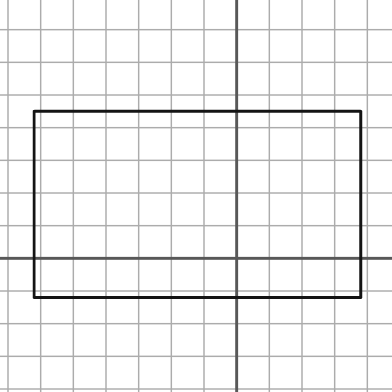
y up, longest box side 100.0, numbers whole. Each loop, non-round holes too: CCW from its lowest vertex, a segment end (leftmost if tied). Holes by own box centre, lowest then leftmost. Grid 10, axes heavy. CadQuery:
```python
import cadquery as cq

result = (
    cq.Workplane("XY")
    .moveTo(-62.0, -12.0)
    .lineTo(38.0, -12.0)
    .lineTo(38.0, 45.0)
    .lineTo(-62.0, 45.0)
    .close()
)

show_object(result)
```